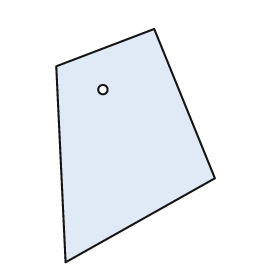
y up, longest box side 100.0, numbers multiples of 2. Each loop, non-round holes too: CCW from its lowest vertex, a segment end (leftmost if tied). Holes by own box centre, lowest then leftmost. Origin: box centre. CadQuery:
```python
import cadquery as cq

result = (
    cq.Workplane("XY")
    .moveTo(-30.0, -50.0)
    .lineTo(34.0, -14.0)
    .lineTo(8.0, 50.0)
    .lineTo(-34.0, 34.0)
    .close()
    .moveTo(-14.0, 24.0)
    .circle(2.0)
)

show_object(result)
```